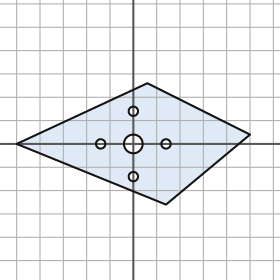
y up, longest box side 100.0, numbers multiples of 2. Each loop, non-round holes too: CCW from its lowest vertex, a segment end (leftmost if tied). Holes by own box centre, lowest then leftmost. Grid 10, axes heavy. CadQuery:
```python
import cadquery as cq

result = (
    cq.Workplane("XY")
    .moveTo(14.0, -26.0)
    .lineTo(50.0, 4.0)
    .lineTo(6.0, 26.0)
    .lineTo(-50.0, 0.0)
    .close()
    .moveTo(0.0, -14.0)
    .circle(2.0)
    .moveTo(-14.0, 0.0)
    .circle(2.0)
    .moveTo(0.0, 0.0)
    .circle(4.0)
    .moveTo(14.0, 0.0)
    .circle(2.0)
    .moveTo(0.0, 14.0)
    .circle(2.0)
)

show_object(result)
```